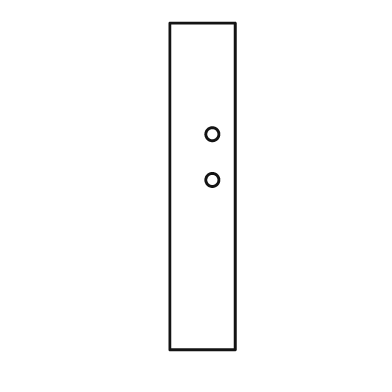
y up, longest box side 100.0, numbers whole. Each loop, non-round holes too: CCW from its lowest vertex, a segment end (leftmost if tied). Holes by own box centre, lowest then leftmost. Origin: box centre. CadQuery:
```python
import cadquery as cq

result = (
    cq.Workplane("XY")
    .moveTo(-10.0, -50.0)
    .lineTo(10.0, -50.0)
    .lineTo(10.0, 50.0)
    .lineTo(-10.0, 50.0)
    .close()
    .moveTo(3.0, 2.0)
    .circle(2.0)
    .moveTo(3.0, 16.0)
    .circle(2.0)
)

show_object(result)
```